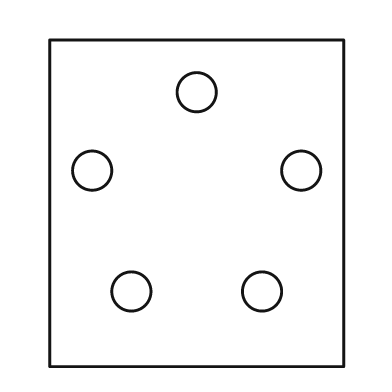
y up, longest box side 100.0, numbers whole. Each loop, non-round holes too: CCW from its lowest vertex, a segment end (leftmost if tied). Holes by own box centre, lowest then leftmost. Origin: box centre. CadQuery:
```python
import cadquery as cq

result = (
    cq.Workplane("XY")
    .moveTo(-45.0, -50.0)
    .lineTo(45.0, -50.0)
    .lineTo(45.0, 50.0)
    .lineTo(-45.0, 50.0)
    .close()
    .moveTo(-20.0, -27.0)
    .circle(6.0)
    .moveTo(20.0, -27.0)
    .circle(6.0)
    .moveTo(-32.0, 10.0)
    .circle(6.0)
    .moveTo(32.0, 10.0)
    .circle(6.0)
    .moveTo(0.0, 34.0)
    .circle(6.0)
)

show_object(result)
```